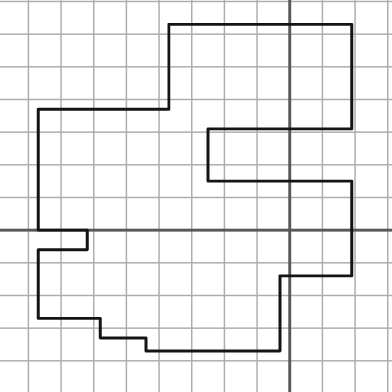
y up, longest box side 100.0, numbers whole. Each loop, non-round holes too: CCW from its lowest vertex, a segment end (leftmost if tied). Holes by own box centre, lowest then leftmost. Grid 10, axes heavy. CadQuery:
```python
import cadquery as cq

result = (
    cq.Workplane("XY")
    .moveTo(-44.0, -37.0)
    .lineTo(-3.0, -37.0)
    .lineTo(-3.0, -14.0)
    .lineTo(19.0, -14.0)
    .lineTo(19.0, 15.0)
    .lineTo(-25.0, 15.0)
    .lineTo(-25.0, 31.0)
    .lineTo(19.0, 31.0)
    .lineTo(19.0, 63.0)
    .lineTo(-37.0, 63.0)
    .lineTo(-37.0, 37.0)
    .lineTo(-77.0, 37.0)
    .lineTo(-77.0, 0.0)
    .lineTo(-62.0, 0.0)
    .lineTo(-62.0, -6.0)
    .lineTo(-77.0, -6.0)
    .lineTo(-77.0, -27.0)
    .lineTo(-58.0, -27.0)
    .lineTo(-58.0, -33.0)
    .lineTo(-44.0, -33.0)
    .close()
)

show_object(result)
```